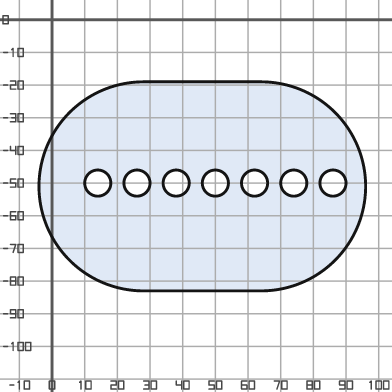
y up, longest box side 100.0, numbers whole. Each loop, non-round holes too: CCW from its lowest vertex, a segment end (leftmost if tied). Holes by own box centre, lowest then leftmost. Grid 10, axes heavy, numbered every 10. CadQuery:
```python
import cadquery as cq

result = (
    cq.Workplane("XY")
    .moveTo(28.0, -83.0)
    .lineTo(64.0, -83.0)
    .threePointArc((96.0, -51.0), (64.0, -19.0))
    .lineTo(28.0, -19.0)
    .threePointArc((-4.0, -51.0), (28.0, -83.0))
    .close()
    .moveTo(14.0, -50.0)
    .circle(4.0)
    .moveTo(26.0, -50.0)
    .circle(4.0)
    .moveTo(38.0, -50.0)
    .circle(4.0)
    .moveTo(50.0, -50.0)
    .circle(4.0)
    .moveTo(62.0, -50.0)
    .circle(4.0)
    .moveTo(74.0, -50.0)
    .circle(4.0)
    .moveTo(86.0, -50.0)
    .circle(4.0)
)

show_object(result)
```